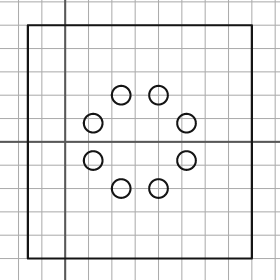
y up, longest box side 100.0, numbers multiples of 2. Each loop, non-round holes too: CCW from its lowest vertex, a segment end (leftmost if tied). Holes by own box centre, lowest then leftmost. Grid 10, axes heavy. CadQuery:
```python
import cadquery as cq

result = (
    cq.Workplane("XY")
    .moveTo(-16.0, -50.0)
    .lineTo(80.0, -50.0)
    .lineTo(80.0, 50.0)
    .lineTo(-16.0, 50.0)
    .close()
    .moveTo(24.0, -20.0)
    .circle(4.0)
    .moveTo(40.0, -20.0)
    .circle(4.0)
    .moveTo(12.0, -8.0)
    .circle(4.0)
    .moveTo(52.0, -8.0)
    .circle(4.0)
    .moveTo(12.0, 8.0)
    .circle(4.0)
    .moveTo(52.0, 8.0)
    .circle(4.0)
    .moveTo(24.0, 20.0)
    .circle(4.0)
    .moveTo(40.0, 20.0)
    .circle(4.0)
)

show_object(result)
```